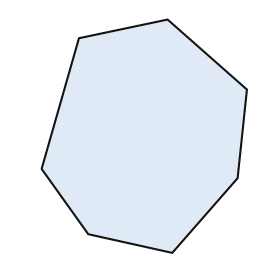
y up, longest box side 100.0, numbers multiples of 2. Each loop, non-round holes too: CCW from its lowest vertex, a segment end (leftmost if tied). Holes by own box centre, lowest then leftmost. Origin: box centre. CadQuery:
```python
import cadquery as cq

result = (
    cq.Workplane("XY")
    .moveTo(12.0, -50.0)
    .lineTo(40.0, -18.0)
    .lineTo(44.0, 20.0)
    .lineTo(10.0, 50.0)
    .lineTo(-28.0, 42.0)
    .lineTo(-44.0, -14.0)
    .lineTo(-24.0, -42.0)
    .close()
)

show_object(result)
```